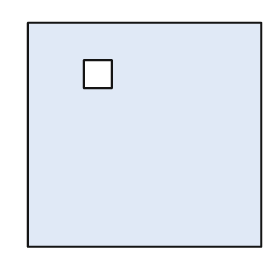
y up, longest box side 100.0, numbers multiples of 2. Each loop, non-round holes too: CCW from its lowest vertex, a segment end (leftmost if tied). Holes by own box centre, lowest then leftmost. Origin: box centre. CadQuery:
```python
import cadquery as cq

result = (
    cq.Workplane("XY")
    .moveTo(-50.0, -48.0)
    .lineTo(50.0, -48.0)
    .lineTo(50.0, 48.0)
    .lineTo(-50.0, 48.0)
    .close()
    .moveTo(-26.0, 20.0)
    .lineTo(-14.0, 20.0)
    .lineTo(-14.0, 32.0)
    .lineTo(-26.0, 32.0)
    .close()
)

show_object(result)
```